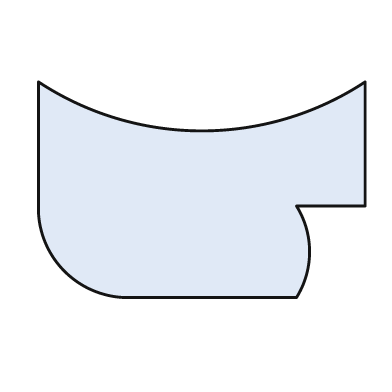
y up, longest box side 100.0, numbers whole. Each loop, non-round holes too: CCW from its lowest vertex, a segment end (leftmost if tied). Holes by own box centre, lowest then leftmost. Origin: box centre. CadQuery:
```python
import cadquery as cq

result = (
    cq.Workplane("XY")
    .moveTo(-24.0, -33.0)
    .lineTo(29.0, -33.0)
    .threePointArc((33.0, -19.0), (29.0, -5.0))
    .lineTo(50.0, -5.0)
    .lineTo(50.0, 33.0)
    .threePointArc((0.0, 18.0), (-50.0, 33.0))
    .lineTo(-50.0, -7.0)
    .threePointArc((-42.0, -25.0), (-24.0, -33.0))
    .close()
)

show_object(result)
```